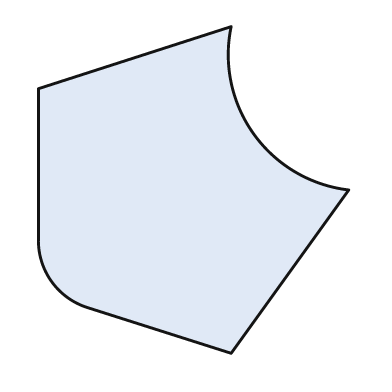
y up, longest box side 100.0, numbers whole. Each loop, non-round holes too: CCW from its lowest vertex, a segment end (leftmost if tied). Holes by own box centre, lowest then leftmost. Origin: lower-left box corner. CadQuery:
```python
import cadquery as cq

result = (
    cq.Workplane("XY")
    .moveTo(59.0, 0.0)
    .lineTo(95.0, 50.0)
    .threePointArc((66.0, 67.0), (59.0, 100.0))
    .lineTo(0.0, 81.0)
    .lineTo(0.0, 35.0)
    .threePointArc((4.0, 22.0), (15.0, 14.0))
    .close()
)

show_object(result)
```